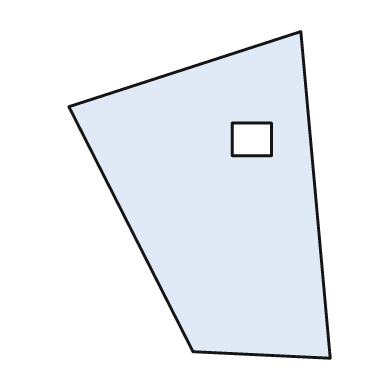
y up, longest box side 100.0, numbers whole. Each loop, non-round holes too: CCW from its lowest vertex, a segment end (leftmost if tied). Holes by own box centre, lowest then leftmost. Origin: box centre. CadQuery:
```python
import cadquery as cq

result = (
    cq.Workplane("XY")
    .moveTo(40.0, -50.0)
    .lineTo(31.0, 50.0)
    .lineTo(-40.0, 27.0)
    .lineTo(-2.0, -48.0)
    .close()
    .moveTo(10.0, 12.0)
    .lineTo(22.0, 12.0)
    .lineTo(22.0, 22.0)
    .lineTo(10.0, 22.0)
    .close()
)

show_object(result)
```